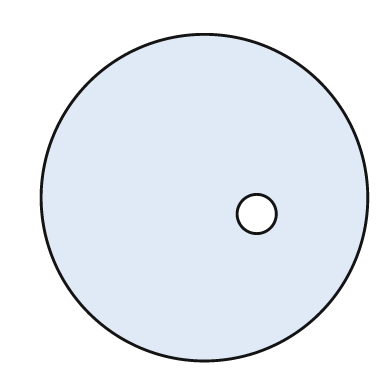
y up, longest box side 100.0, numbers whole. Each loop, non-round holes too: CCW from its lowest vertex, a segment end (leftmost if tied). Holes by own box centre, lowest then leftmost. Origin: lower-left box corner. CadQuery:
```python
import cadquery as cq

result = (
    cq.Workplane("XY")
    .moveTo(50.0, 50.0)
    .circle(50.0)
    .moveTo(66.0, 45.0)
    .circle(6.0)
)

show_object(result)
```